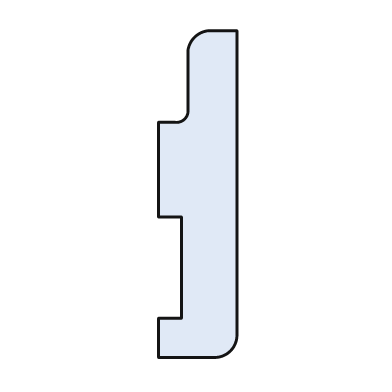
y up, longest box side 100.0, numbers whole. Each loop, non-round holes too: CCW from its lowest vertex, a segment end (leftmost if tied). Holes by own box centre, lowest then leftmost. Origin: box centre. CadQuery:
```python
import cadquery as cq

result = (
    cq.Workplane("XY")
    .moveTo(-12.0, -50.0)
    .lineTo(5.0, -50.0)
    .threePointArc((10.0, -48.0), (12.0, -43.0))
    .lineTo(12.0, 50.0)
    .lineTo(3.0, 50.0)
    .threePointArc((-1.0, 48.0), (-3.0, 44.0))
    .lineTo(-3.0, 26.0)
    .threePointArc((-4.0, 23.0), (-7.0, 22.0))
    .lineTo(-12.0, 22.0)
    .lineTo(-12.0, -7.0)
    .lineTo(-5.0, -7.0)
    .lineTo(-5.0, -38.0)
    .lineTo(-12.0, -38.0)
    .close()
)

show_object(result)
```